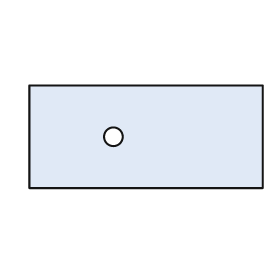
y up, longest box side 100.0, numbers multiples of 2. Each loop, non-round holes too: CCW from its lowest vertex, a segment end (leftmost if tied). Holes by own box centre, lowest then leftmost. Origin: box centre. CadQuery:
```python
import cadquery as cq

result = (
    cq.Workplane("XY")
    .moveTo(-50.0, -22.0)
    .lineTo(50.0, -22.0)
    .lineTo(50.0, 22.0)
    .lineTo(-50.0, 22.0)
    .close()
    .moveTo(-14.0, 0.0)
    .circle(4.0)
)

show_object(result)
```